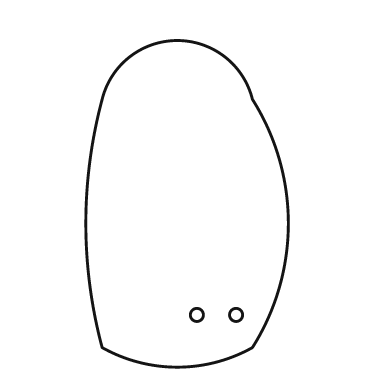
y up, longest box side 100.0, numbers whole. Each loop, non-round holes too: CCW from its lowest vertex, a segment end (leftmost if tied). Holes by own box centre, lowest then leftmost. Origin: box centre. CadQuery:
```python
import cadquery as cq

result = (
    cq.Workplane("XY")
    .moveTo(-26.0, -44.0)
    .threePointArc((-3.0, -50.0), (20.0, -44.0))
    .threePointArc((31.0, -6.0), (20.0, 32.0))
    .threePointArc((-3.0, 50.0), (-26.0, 32.0))
    .threePointArc((-31.0, -6.0), (-26.0, -44.0))
    .close()
    .moveTo(3.0, -34.0)
    .circle(2.0)
    .moveTo(15.0, -34.0)
    .circle(2.0)
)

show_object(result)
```